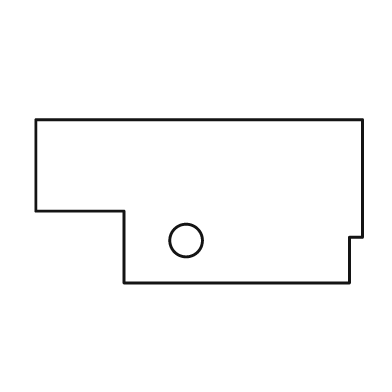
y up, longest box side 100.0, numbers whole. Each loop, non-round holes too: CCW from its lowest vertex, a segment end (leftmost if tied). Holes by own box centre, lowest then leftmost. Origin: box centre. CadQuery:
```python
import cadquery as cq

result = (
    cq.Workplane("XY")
    .moveTo(-23.0, -25.0)
    .lineTo(46.0, -25.0)
    .lineTo(46.0, -11.0)
    .lineTo(50.0, -11.0)
    .lineTo(50.0, 25.0)
    .lineTo(-50.0, 25.0)
    .lineTo(-50.0, -3.0)
    .lineTo(-23.0, -3.0)
    .close()
    .moveTo(-4.0, -12.0)
    .circle(5.0)
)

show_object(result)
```